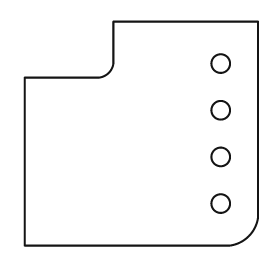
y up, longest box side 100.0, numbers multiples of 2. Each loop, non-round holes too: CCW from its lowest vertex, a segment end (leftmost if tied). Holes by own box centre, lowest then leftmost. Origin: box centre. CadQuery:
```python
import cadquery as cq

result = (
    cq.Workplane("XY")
    .moveTo(-50.0, -48.0)
    .lineTo(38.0, -48.0)
    .threePointArc((46.0, -44.0), (50.0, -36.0))
    .lineTo(50.0, 48.0)
    .lineTo(-12.0, 48.0)
    .lineTo(-12.0, 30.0)
    .threePointArc((-14.0, 26.0), (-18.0, 24.0))
    .lineTo(-50.0, 24.0)
    .close()
    .moveTo(34.0, -30.0)
    .circle(4.0)
    .moveTo(34.0, -10.0)
    .circle(4.0)
    .moveTo(34.0, 10.0)
    .circle(4.0)
    .moveTo(34.0, 30.0)
    .circle(4.0)
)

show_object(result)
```